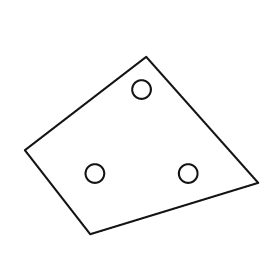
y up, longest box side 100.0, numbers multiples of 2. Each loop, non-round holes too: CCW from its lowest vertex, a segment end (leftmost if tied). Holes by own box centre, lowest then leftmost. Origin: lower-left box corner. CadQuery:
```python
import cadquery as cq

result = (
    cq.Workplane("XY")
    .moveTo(28.0, 0.0)
    .lineTo(100.0, 22.0)
    .lineTo(52.0, 76.0)
    .lineTo(0.0, 36.0)
    .close()
    .moveTo(30.0, 26.0)
    .circle(4.0)
    .moveTo(70.0, 26.0)
    .circle(4.0)
    .moveTo(50.0, 62.0)
    .circle(4.0)
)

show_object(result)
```